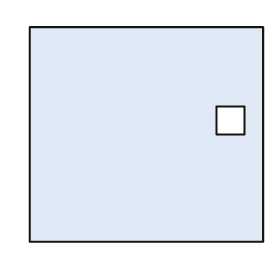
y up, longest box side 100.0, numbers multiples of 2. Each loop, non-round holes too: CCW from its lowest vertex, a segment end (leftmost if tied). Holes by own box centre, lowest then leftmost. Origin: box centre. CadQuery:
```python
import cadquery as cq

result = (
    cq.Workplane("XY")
    .moveTo(-50.0, -46.0)
    .lineTo(50.0, -46.0)
    .lineTo(50.0, 46.0)
    .lineTo(-50.0, 46.0)
    .close()
    .moveTo(30.0, 0.0)
    .lineTo(42.0, 0.0)
    .lineTo(42.0, 12.0)
    .lineTo(30.0, 12.0)
    .close()
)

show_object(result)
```